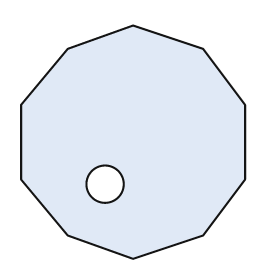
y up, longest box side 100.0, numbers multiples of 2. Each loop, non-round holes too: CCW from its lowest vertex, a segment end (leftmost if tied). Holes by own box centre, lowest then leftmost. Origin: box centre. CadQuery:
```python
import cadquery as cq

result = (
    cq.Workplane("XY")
    .moveTo(0.0, -50.0)
    .lineTo(30.0, -40.0)
    .lineTo(48.0, -16.0)
    .lineTo(48.0, 16.0)
    .lineTo(30.0, 40.0)
    .lineTo(0.0, 50.0)
    .lineTo(-28.0, 40.0)
    .lineTo(-48.0, 16.0)
    .lineTo(-48.0, -16.0)
    .lineTo(-28.0, -40.0)
    .close()
    .moveTo(-12.0, -18.0)
    .circle(8.0)
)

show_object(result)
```